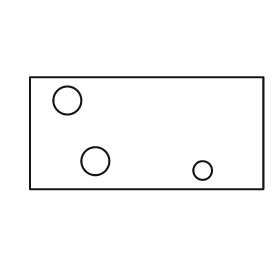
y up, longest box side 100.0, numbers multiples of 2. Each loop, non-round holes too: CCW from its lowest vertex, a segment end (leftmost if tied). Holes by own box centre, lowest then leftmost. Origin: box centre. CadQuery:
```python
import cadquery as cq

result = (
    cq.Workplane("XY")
    .moveTo(-50.0, -24.0)
    .lineTo(50.0, -24.0)
    .lineTo(50.0, 24.0)
    .lineTo(-50.0, 24.0)
    .close()
    .moveTo(24.0, -16.0)
    .circle(4.0)
    .moveTo(-22.0, -12.0)
    .circle(6.0)
    .moveTo(-34.0, 14.0)
    .circle(6.0)
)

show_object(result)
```